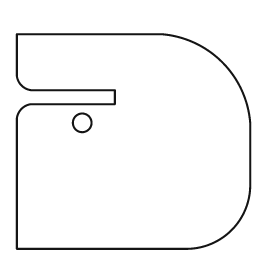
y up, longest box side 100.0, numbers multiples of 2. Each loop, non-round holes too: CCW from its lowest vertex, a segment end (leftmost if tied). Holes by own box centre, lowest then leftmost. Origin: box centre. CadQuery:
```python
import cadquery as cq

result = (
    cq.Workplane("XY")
    .moveTo(-50.0, -46.0)
    .lineTo(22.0, -46.0)
    .threePointArc((42.0, -38.0), (50.0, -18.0))
    .lineTo(50.0, 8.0)
    .threePointArc((38.0, 34.0), (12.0, 46.0))
    .lineTo(-50.0, 46.0)
    .lineTo(-50.0, 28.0)
    .threePointArc((-48.0, 24.0), (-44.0, 22.0))
    .lineTo(-8.0, 22.0)
    .lineTo(-8.0, 16.0)
    .lineTo(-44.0, 16.0)
    .threePointArc((-48.0, 14.0), (-50.0, 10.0))
    .close()
    .moveTo(-22.0, 8.0)
    .circle(4.0)
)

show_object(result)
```